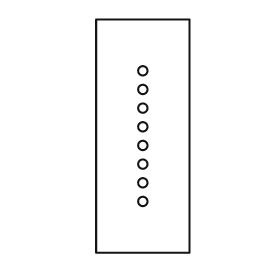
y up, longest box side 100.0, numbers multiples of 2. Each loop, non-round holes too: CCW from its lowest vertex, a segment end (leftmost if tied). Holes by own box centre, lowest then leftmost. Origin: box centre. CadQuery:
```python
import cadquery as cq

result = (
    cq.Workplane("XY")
    .moveTo(-20.0, -50.0)
    .lineTo(20.0, -50.0)
    .lineTo(20.0, 50.0)
    .lineTo(-20.0, 50.0)
    .close()
    .moveTo(0.0, -28.0)
    .circle(2.0)
    .moveTo(0.0, -20.0)
    .circle(2.0)
    .moveTo(0.0, -12.0)
    .circle(2.0)
    .moveTo(0.0, -4.0)
    .circle(2.0)
    .moveTo(0.0, 4.0)
    .circle(2.0)
    .moveTo(0.0, 12.0)
    .circle(2.0)
    .moveTo(0.0, 20.0)
    .circle(2.0)
    .moveTo(0.0, 28.0)
    .circle(2.0)
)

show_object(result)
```